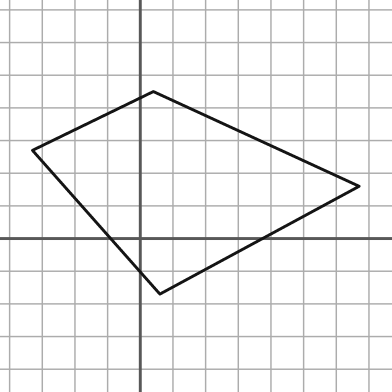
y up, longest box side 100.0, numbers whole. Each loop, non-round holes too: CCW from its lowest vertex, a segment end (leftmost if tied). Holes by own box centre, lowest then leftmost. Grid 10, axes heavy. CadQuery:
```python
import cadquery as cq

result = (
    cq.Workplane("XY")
    .moveTo(6.0, -17.0)
    .lineTo(67.0, 16.0)
    .lineTo(4.0, 45.0)
    .lineTo(-33.0, 27.0)
    .close()
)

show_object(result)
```